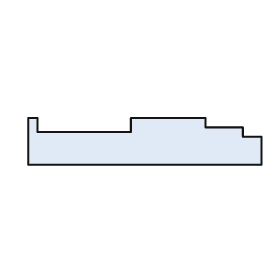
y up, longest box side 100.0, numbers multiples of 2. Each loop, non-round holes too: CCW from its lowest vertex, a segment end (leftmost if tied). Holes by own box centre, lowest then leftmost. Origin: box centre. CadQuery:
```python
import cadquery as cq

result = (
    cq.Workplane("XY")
    .moveTo(-50.0, -10.0)
    .lineTo(50.0, -10.0)
    .lineTo(50.0, 2.0)
    .lineTo(42.0, 2.0)
    .lineTo(42.0, 6.0)
    .lineTo(26.0, 6.0)
    .lineTo(26.0, 10.0)
    .lineTo(-6.0, 10.0)
    .lineTo(-6.0, 4.0)
    .lineTo(-46.0, 4.0)
    .lineTo(-46.0, 10.0)
    .lineTo(-50.0, 10.0)
    .close()
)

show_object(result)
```